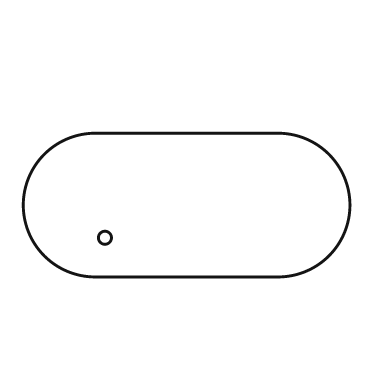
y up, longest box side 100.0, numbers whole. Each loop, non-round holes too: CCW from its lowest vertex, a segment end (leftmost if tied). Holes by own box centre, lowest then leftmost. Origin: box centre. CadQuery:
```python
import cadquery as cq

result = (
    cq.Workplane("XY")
    .moveTo(-28.0, -22.0)
    .lineTo(28.0, -22.0)
    .threePointArc((50.0, 0.0), (28.0, 22.0))
    .lineTo(-28.0, 22.0)
    .threePointArc((-50.0, 0.0), (-28.0, -22.0))
    .close()
    .moveTo(-25.0, -10.0)
    .circle(2.0)
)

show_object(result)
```